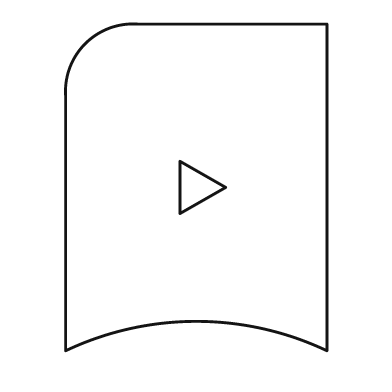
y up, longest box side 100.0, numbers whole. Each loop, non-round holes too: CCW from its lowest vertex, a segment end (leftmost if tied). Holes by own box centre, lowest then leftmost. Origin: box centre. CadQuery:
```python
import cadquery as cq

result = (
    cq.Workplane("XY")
    .moveTo(-40.0, -50.0)
    .threePointArc((0.0, -41.0), (40.0, -50.0))
    .lineTo(40.0, 50.0)
    .lineTo(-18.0, 50.0)
    .threePointArc((-34.0, 44.0), (-40.0, 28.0))
    .close()
    .moveTo(-5.0, -8.0)
    .lineTo(9.0, 0.0)
    .lineTo(-5.0, 8.0)
    .close()
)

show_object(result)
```